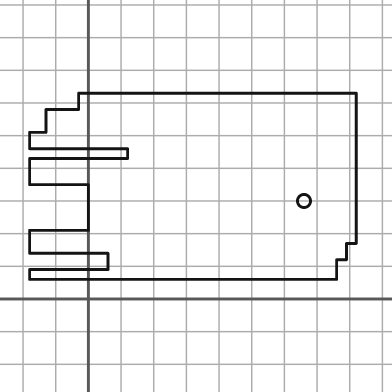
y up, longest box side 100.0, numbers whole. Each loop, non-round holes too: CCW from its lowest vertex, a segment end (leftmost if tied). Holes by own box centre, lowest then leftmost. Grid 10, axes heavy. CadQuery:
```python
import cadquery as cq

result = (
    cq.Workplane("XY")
    .moveTo(-18.0, 6.0)
    .lineTo(76.0, 6.0)
    .lineTo(76.0, 12.0)
    .lineTo(79.0, 12.0)
    .lineTo(79.0, 17.0)
    .lineTo(82.0, 17.0)
    .lineTo(82.0, 63.0)
    .lineTo(-3.0, 63.0)
    .lineTo(-3.0, 58.0)
    .lineTo(-13.0, 58.0)
    .lineTo(-13.0, 51.0)
    .lineTo(-18.0, 51.0)
    .lineTo(-18.0, 46.0)
    .lineTo(12.0, 46.0)
    .lineTo(12.0, 43.0)
    .lineTo(-18.0, 43.0)
    .lineTo(-18.0, 35.0)
    .lineTo(0.0, 35.0)
    .lineTo(0.0, 21.0)
    .lineTo(-18.0, 21.0)
    .lineTo(-18.0, 14.0)
    .lineTo(6.0, 14.0)
    .lineTo(6.0, 9.0)
    .lineTo(-18.0, 9.0)
    .close()
    .moveTo(66.0, 30.0)
    .circle(2.0)
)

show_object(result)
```